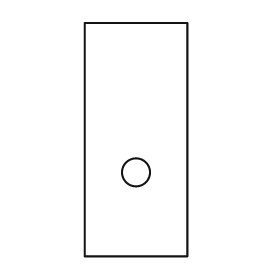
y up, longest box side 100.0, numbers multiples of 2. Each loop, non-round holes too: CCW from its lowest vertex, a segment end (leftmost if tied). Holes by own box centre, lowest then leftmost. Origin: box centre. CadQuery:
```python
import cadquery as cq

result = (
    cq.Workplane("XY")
    .moveTo(-22.0, -50.0)
    .lineTo(22.0, -50.0)
    .lineTo(22.0, 50.0)
    .lineTo(-22.0, 50.0)
    .close()
    .moveTo(0.0, -14.0)
    .circle(6.0)
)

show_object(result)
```